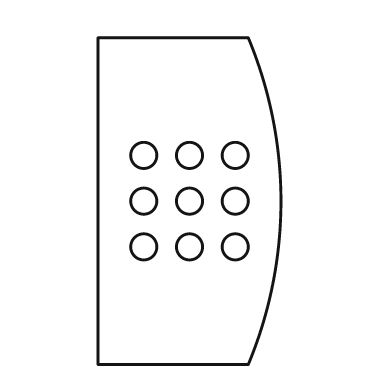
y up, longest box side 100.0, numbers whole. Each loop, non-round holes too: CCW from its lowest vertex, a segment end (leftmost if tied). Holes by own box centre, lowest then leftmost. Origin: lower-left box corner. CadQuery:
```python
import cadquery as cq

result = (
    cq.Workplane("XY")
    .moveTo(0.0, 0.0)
    .lineTo(46.0, 0.0)
    .threePointArc((56.0, 50.0), (46.0, 100.0))
    .lineTo(0.0, 100.0)
    .close()
    .moveTo(14.0, 36.0)
    .circle(4.0)
    .moveTo(28.0, 36.0)
    .circle(4.0)
    .moveTo(42.0, 36.0)
    .circle(4.0)
    .moveTo(14.0, 50.0)
    .circle(4.0)
    .moveTo(28.0, 50.0)
    .circle(4.0)
    .moveTo(42.0, 50.0)
    .circle(4.0)
    .moveTo(14.0, 64.0)
    .circle(4.0)
    .moveTo(28.0, 64.0)
    .circle(4.0)
    .moveTo(42.0, 64.0)
    .circle(4.0)
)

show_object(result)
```